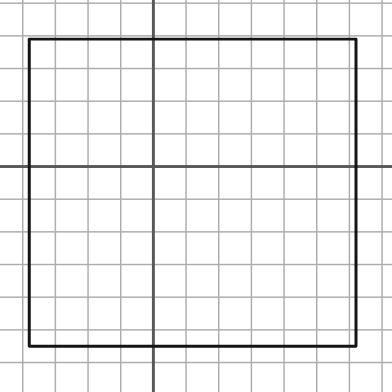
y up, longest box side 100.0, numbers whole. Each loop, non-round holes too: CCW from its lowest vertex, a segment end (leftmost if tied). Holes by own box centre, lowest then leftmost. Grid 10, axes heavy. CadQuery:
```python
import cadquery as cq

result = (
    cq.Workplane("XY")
    .moveTo(-38.0, -55.0)
    .lineTo(62.0, -55.0)
    .lineTo(62.0, 39.0)
    .lineTo(-38.0, 39.0)
    .close()
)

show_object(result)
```